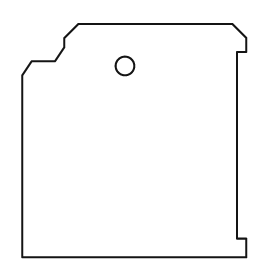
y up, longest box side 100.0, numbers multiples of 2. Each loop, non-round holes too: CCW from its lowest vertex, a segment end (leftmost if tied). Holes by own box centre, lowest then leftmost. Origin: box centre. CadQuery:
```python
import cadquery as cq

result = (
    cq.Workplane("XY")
    .moveTo(-48.0, -50.0)
    .lineTo(48.0, -50.0)
    .lineTo(48.0, -42.0)
    .lineTo(44.0, -42.0)
    .lineTo(44.0, 38.0)
    .lineTo(48.0, 38.0)
    .lineTo(48.0, 44.0)
    .lineTo(42.0, 50.0)
    .lineTo(-24.0, 50.0)
    .lineTo(-30.0, 44.0)
    .lineTo(-30.0, 40.0)
    .lineTo(-34.0, 34.0)
    .lineTo(-44.0, 34.0)
    .lineTo(-48.0, 28.0)
    .close()
    .moveTo(-4.0, 32.0)
    .circle(4.0)
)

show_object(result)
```